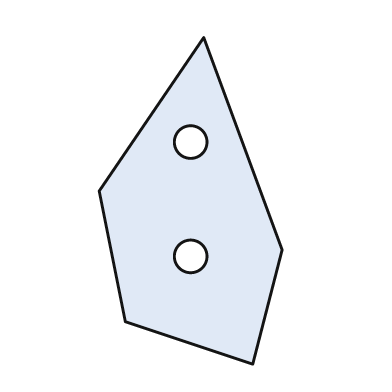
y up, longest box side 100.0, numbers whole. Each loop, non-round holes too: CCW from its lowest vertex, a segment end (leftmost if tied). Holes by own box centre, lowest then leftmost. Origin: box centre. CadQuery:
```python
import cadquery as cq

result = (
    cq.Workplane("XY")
    .moveTo(19.0, -50.0)
    .lineTo(28.0, -15.0)
    .lineTo(4.0, 50.0)
    .lineTo(-28.0, 3.0)
    .lineTo(-20.0, -37.0)
    .close()
    .moveTo(0.0, -17.0)
    .circle(5.0)
    .moveTo(0.0, 18.0)
    .circle(5.0)
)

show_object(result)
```